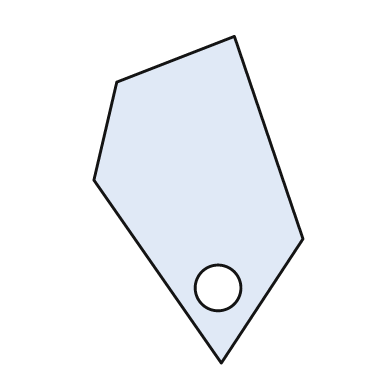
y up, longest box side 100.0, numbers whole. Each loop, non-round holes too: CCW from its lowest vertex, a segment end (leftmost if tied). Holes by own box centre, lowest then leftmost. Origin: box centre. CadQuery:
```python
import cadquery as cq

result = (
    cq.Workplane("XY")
    .moveTo(7.0, -50.0)
    .lineTo(32.0, -12.0)
    .lineTo(11.0, 50.0)
    .lineTo(-25.0, 36.0)
    .lineTo(-32.0, 6.0)
    .close()
    .moveTo(6.0, -27.0)
    .circle(7.0)
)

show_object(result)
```